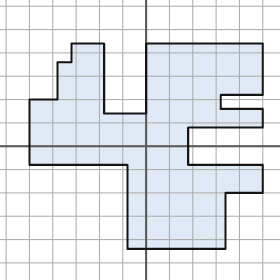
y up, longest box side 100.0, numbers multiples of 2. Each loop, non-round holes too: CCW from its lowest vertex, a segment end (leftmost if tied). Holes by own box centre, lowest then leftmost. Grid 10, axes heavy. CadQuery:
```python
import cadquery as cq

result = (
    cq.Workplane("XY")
    .moveTo(-8.0, -44.0)
    .lineTo(34.0, -44.0)
    .lineTo(34.0, -20.0)
    .lineTo(50.0, -20.0)
    .lineTo(50.0, -8.0)
    .lineTo(18.0, -8.0)
    .lineTo(18.0, 8.0)
    .lineTo(50.0, 8.0)
    .lineTo(50.0, 16.0)
    .lineTo(32.0, 16.0)
    .lineTo(32.0, 22.0)
    .lineTo(50.0, 22.0)
    .lineTo(50.0, 44.0)
    .lineTo(0.0, 44.0)
    .lineTo(0.0, 14.0)
    .lineTo(-18.0, 14.0)
    .lineTo(-18.0, 44.0)
    .lineTo(-32.0, 44.0)
    .lineTo(-32.0, 36.0)
    .lineTo(-38.0, 36.0)
    .lineTo(-38.0, 20.0)
    .lineTo(-50.0, 20.0)
    .lineTo(-50.0, -8.0)
    .lineTo(-8.0, -8.0)
    .close()
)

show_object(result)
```